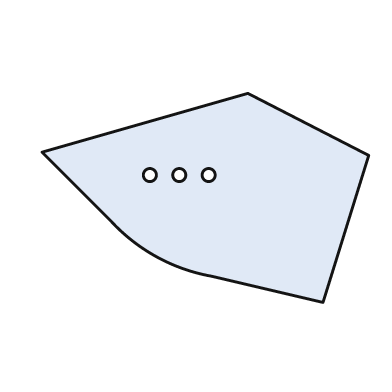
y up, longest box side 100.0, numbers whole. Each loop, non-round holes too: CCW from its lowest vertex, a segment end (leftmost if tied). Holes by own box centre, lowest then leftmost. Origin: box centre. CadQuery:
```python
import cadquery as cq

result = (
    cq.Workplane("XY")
    .moveTo(36.0, -32.0)
    .lineTo(50.0, 13.0)
    .lineTo(13.0, 32.0)
    .lineTo(-50.0, 14.0)
    .lineTo(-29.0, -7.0)
    .threePointArc((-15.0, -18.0), (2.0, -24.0))
    .close()
    .moveTo(-17.0, 7.0)
    .circle(2.0)
    .moveTo(-8.0, 7.0)
    .circle(2.0)
    .moveTo(1.0, 7.0)
    .circle(2.0)
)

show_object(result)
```